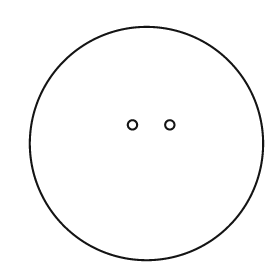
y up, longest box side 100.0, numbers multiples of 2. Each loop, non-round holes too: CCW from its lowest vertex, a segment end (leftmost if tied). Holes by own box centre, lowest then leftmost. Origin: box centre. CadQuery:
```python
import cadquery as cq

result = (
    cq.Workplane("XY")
    .moveTo(0.0, 0.0)
    .circle(50.0)
    .moveTo(-6.0, 8.0)
    .circle(2.0)
    .moveTo(10.0, 8.0)
    .circle(2.0)
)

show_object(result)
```